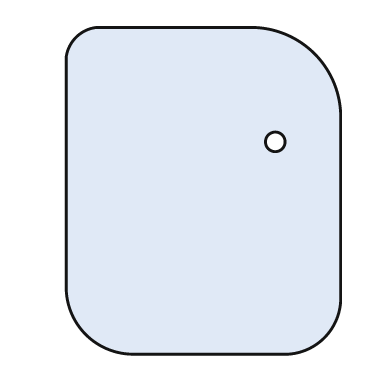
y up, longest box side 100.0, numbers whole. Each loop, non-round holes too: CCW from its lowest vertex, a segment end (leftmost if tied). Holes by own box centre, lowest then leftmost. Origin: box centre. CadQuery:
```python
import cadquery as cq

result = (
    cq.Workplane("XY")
    .moveTo(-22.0, -50.0)
    .lineTo(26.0, -50.0)
    .threePointArc((37.0, -45.0), (42.0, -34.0))
    .lineTo(42.0, 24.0)
    .threePointArc((34.0, 42.0), (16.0, 50.0))
    .lineTo(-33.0, 50.0)
    .threePointArc((-39.0, 47.0), (-42.0, 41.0))
    .lineTo(-42.0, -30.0)
    .threePointArc((-36.0, -44.0), (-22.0, -50.0))
    .close()
    .moveTo(22.0, 15.0)
    .circle(3.0)
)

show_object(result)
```